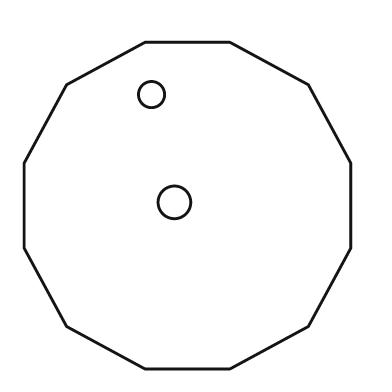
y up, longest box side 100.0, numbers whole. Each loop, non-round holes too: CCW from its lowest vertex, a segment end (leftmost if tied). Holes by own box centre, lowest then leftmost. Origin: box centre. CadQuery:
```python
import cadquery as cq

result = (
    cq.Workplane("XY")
    .moveTo(-13.0, -50.0)
    .lineTo(13.0, -50.0)
    .lineTo(37.0, -37.0)
    .lineTo(50.0, -13.0)
    .lineTo(50.0, 13.0)
    .lineTo(37.0, 37.0)
    .lineTo(13.0, 50.0)
    .lineTo(-13.0, 50.0)
    .lineTo(-37.0, 37.0)
    .lineTo(-50.0, 13.0)
    .lineTo(-50.0, -13.0)
    .lineTo(-37.0, -37.0)
    .close()
    .moveTo(-4.0, 1.0)
    .circle(5.0)
    .moveTo(-11.0, 34.0)
    .circle(4.0)
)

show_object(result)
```